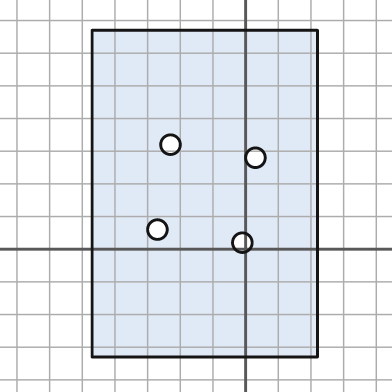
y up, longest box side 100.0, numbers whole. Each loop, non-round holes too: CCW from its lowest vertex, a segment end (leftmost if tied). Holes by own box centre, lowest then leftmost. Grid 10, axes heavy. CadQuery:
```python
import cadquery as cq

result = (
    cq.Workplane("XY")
    .moveTo(-47.0, -33.0)
    .lineTo(22.0, -33.0)
    .lineTo(22.0, 67.0)
    .lineTo(-47.0, 67.0)
    .close()
    .moveTo(-1.0, 2.0)
    .circle(3.0)
    .moveTo(-27.0, 6.0)
    .circle(3.0)
    .moveTo(3.0, 28.0)
    .circle(3.0)
    .moveTo(-23.0, 32.0)
    .circle(3.0)
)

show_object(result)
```